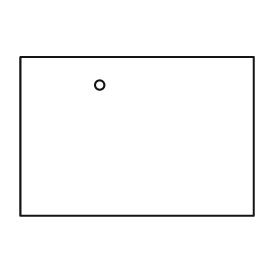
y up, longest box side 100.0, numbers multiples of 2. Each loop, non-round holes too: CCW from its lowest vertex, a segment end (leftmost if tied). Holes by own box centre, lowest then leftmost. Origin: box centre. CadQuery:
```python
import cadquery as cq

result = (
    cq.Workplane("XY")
    .moveTo(-50.0, -34.0)
    .lineTo(50.0, -34.0)
    .lineTo(50.0, 34.0)
    .lineTo(-50.0, 34.0)
    .close()
    .moveTo(-16.0, 22.0)
    .circle(2.0)
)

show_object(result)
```